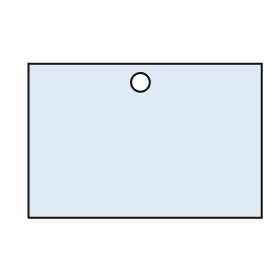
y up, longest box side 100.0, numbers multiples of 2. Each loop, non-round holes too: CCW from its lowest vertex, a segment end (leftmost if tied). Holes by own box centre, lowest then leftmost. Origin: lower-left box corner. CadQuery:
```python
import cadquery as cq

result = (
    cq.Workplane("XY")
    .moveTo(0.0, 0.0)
    .lineTo(100.0, 0.0)
    .lineTo(100.0, 66.0)
    .lineTo(0.0, 66.0)
    .close()
    .moveTo(48.0, 58.0)
    .circle(4.0)
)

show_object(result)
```